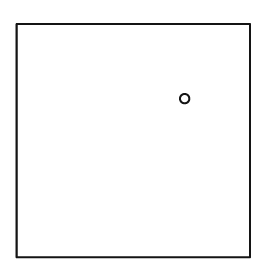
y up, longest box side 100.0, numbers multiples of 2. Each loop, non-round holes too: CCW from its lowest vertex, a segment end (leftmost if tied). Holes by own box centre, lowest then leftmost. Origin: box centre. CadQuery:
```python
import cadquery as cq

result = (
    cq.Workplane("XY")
    .moveTo(-50.0, -50.0)
    .lineTo(50.0, -50.0)
    .lineTo(50.0, 50.0)
    .lineTo(-50.0, 50.0)
    .close()
    .moveTo(22.0, 18.0)
    .circle(2.0)
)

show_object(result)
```